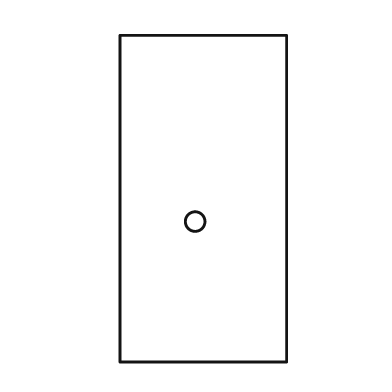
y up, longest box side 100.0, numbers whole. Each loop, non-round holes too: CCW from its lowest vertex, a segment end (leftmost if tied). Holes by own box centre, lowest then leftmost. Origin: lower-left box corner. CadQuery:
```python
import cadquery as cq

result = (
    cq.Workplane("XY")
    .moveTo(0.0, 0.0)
    .lineTo(51.0, 0.0)
    .lineTo(51.0, 100.0)
    .lineTo(0.0, 100.0)
    .close()
    .moveTo(23.0, 43.0)
    .circle(3.0)
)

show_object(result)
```